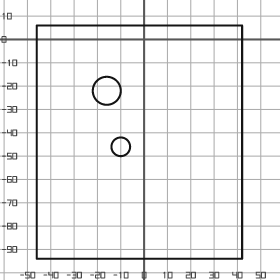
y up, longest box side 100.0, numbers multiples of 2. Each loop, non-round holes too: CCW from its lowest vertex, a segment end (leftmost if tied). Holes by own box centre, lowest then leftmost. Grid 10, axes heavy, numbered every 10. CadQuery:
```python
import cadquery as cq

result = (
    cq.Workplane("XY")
    .moveTo(-46.0, -94.0)
    .lineTo(42.0, -94.0)
    .lineTo(42.0, 6.0)
    .lineTo(-46.0, 6.0)
    .close()
    .moveTo(-10.0, -46.0)
    .circle(4.0)
    .moveTo(-16.0, -22.0)
    .circle(6.0)
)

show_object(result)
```